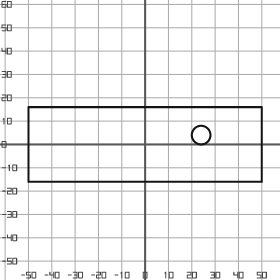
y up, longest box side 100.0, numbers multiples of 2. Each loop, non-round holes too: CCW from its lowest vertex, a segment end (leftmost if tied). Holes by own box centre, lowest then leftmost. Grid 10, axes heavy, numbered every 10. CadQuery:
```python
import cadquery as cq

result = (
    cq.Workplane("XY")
    .moveTo(-50.0, -16.0)
    .lineTo(50.0, -16.0)
    .lineTo(50.0, 16.0)
    .lineTo(-50.0, 16.0)
    .close()
    .moveTo(24.0, 4.0)
    .circle(4.0)
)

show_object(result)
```